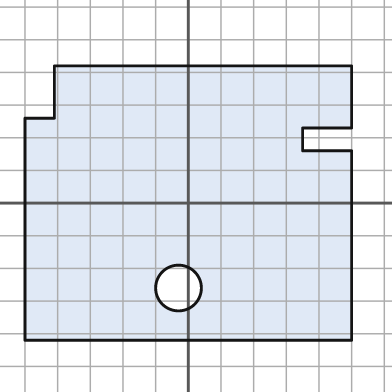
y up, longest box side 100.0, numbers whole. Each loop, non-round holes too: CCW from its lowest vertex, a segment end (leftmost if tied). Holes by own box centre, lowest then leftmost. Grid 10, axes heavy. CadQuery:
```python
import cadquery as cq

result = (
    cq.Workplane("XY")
    .moveTo(-50.0, -42.0)
    .lineTo(50.0, -42.0)
    .lineTo(50.0, 16.0)
    .lineTo(35.0, 16.0)
    .lineTo(35.0, 23.0)
    .lineTo(50.0, 23.0)
    .lineTo(50.0, 42.0)
    .lineTo(-41.0, 42.0)
    .lineTo(-41.0, 26.0)
    .lineTo(-50.0, 26.0)
    .close()
    .moveTo(-3.0, -26.0)
    .circle(7.0)
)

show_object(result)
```